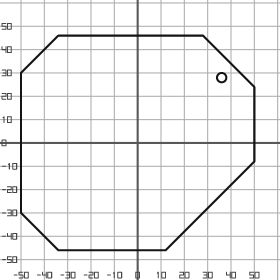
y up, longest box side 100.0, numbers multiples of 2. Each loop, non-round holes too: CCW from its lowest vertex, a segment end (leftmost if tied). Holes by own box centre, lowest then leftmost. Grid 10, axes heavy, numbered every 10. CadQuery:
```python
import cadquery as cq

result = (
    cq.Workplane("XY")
    .moveTo(-34.0, -46.0)
    .lineTo(12.0, -46.0)
    .lineTo(50.0, -8.0)
    .lineTo(50.0, 24.0)
    .lineTo(28.0, 46.0)
    .lineTo(-34.0, 46.0)
    .lineTo(-50.0, 30.0)
    .lineTo(-50.0, -30.0)
    .close()
    .moveTo(36.0, 28.0)
    .circle(2.0)
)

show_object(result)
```